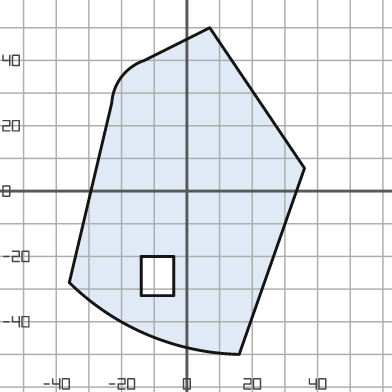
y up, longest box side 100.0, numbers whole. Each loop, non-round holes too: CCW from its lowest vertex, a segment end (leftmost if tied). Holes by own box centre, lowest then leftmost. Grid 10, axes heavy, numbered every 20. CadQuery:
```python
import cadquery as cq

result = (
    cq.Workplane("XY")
    .moveTo(16.0, -50.0)
    .lineTo(36.0, 7.0)
    .lineTo(7.0, 50.0)
    .lineTo(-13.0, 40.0)
    .threePointArc((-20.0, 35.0), (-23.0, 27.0))
    .lineTo(-36.0, -28.0)
    .threePointArc((-12.0, -44.0), (16.0, -50.0))
    .close()
    .moveTo(-14.0, -32.0)
    .lineTo(-4.0, -32.0)
    .lineTo(-4.0, -20.0)
    .lineTo(-14.0, -20.0)
    .close()
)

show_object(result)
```